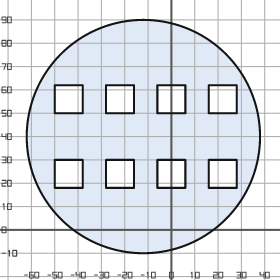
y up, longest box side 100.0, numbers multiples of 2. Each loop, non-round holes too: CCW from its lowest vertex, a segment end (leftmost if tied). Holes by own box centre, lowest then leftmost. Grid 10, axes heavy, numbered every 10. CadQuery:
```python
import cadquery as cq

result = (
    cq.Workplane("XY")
    .moveTo(-12.0, 40.0)
    .circle(50.0)
    .moveTo(-50.0, 18.0)
    .lineTo(-38.0, 18.0)
    .lineTo(-38.0, 30.0)
    .lineTo(-50.0, 30.0)
    .close()
    .moveTo(-28.0, 18.0)
    .lineTo(-16.0, 18.0)
    .lineTo(-16.0, 30.0)
    .lineTo(-28.0, 30.0)
    .close()
    .moveTo(-6.0, 18.0)
    .lineTo(6.0, 18.0)
    .lineTo(6.0, 30.0)
    .lineTo(-6.0, 30.0)
    .close()
    .moveTo(16.0, 18.0)
    .lineTo(28.0, 18.0)
    .lineTo(28.0, 30.0)
    .lineTo(16.0, 30.0)
    .close()
    .moveTo(-50.0, 50.0)
    .lineTo(-38.0, 50.0)
    .lineTo(-38.0, 62.0)
    .lineTo(-50.0, 62.0)
    .close()
    .moveTo(-28.0, 50.0)
    .lineTo(-16.0, 50.0)
    .lineTo(-16.0, 62.0)
    .lineTo(-28.0, 62.0)
    .close()
    .moveTo(-6.0, 50.0)
    .lineTo(6.0, 50.0)
    .lineTo(6.0, 62.0)
    .lineTo(-6.0, 62.0)
    .close()
    .moveTo(16.0, 50.0)
    .lineTo(28.0, 50.0)
    .lineTo(28.0, 62.0)
    .lineTo(16.0, 62.0)
    .close()
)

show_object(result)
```